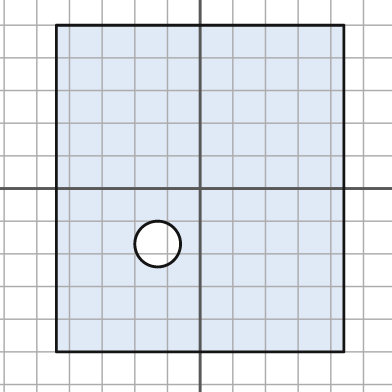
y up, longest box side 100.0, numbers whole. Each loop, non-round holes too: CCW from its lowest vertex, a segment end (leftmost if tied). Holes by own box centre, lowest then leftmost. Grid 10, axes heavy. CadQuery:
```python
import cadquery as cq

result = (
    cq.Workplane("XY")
    .moveTo(-44.0, -50.0)
    .lineTo(44.0, -50.0)
    .lineTo(44.0, 50.0)
    .lineTo(-44.0, 50.0)
    .close()
    .moveTo(-13.0, -17.0)
    .circle(7.0)
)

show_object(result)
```